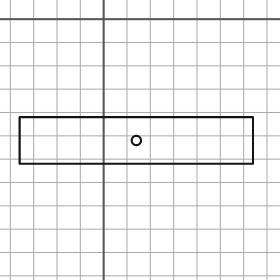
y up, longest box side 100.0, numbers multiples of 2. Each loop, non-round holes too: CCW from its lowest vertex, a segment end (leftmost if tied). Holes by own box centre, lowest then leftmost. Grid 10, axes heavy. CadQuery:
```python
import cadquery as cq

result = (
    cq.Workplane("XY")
    .moveTo(-36.0, -62.0)
    .lineTo(64.0, -62.0)
    .lineTo(64.0, -42.0)
    .lineTo(-36.0, -42.0)
    .close()
    .moveTo(14.0, -52.0)
    .circle(2.0)
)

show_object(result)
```